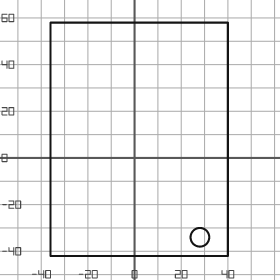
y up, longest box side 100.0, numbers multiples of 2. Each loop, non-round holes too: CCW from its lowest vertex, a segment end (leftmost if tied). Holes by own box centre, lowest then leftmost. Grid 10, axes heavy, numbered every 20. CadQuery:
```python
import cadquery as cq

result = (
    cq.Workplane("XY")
    .moveTo(-36.0, -42.0)
    .lineTo(40.0, -42.0)
    .lineTo(40.0, 58.0)
    .lineTo(-36.0, 58.0)
    .close()
    .moveTo(28.0, -34.0)
    .circle(4.0)
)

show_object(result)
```